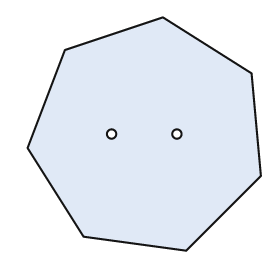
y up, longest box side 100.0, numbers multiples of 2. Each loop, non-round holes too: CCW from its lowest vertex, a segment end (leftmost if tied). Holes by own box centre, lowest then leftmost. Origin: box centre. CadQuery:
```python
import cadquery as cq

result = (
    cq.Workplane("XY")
    .moveTo(18.0, -50.0)
    .lineTo(50.0, -18.0)
    .lineTo(46.0, 26.0)
    .lineTo(8.0, 50.0)
    .lineTo(-34.0, 36.0)
    .lineTo(-50.0, -6.0)
    .lineTo(-26.0, -44.0)
    .close()
    .moveTo(-14.0, 0.0)
    .circle(2.0)
    .moveTo(14.0, 0.0)
    .circle(2.0)
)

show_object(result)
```